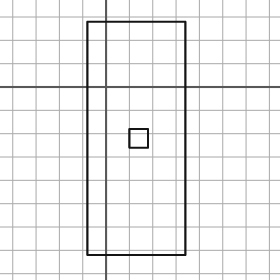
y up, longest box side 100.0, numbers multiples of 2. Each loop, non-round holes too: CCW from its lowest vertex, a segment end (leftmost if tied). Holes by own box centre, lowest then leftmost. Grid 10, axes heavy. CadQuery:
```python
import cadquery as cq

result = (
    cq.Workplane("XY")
    .moveTo(-8.0, -72.0)
    .lineTo(34.0, -72.0)
    .lineTo(34.0, 28.0)
    .lineTo(-8.0, 28.0)
    .close()
    .moveTo(10.0, -26.0)
    .lineTo(18.0, -26.0)
    .lineTo(18.0, -18.0)
    .lineTo(10.0, -18.0)
    .close()
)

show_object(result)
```